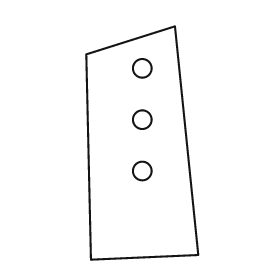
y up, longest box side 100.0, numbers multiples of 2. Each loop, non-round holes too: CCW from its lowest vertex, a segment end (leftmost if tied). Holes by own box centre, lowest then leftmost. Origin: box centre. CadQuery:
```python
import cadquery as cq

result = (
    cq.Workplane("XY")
    .moveTo(-22.0, -50.0)
    .lineTo(24.0, -48.0)
    .lineTo(14.0, 50.0)
    .lineTo(-24.0, 38.0)
    .close()
    .moveTo(0.0, -12.0)
    .circle(4.0)
    .moveTo(0.0, 10.0)
    .circle(4.0)
    .moveTo(0.0, 32.0)
    .circle(4.0)
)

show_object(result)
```